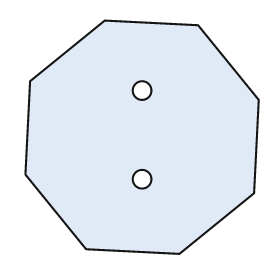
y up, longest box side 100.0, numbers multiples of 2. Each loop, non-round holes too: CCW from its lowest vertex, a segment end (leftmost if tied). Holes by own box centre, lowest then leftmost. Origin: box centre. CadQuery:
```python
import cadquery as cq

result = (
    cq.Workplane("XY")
    .moveTo(16.0, -50.0)
    .lineTo(48.0, -24.0)
    .lineTo(50.0, 16.0)
    .lineTo(24.0, 48.0)
    .lineTo(-16.0, 50.0)
    .lineTo(-48.0, 24.0)
    .lineTo(-50.0, -16.0)
    .lineTo(-24.0, -48.0)
    .close()
    .moveTo(0.0, -18.0)
    .circle(4.0)
    .moveTo(0.0, 20.0)
    .circle(4.0)
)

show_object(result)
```